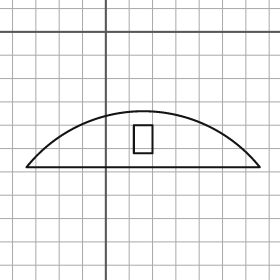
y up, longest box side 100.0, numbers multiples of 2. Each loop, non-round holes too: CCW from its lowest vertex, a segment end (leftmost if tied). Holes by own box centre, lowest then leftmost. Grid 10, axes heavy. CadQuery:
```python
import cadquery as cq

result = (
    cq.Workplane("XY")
    .moveTo(-34.0, -58.0)
    .lineTo(66.0, -58.0)
    .threePointArc((16.0, -34.0), (-34.0, -58.0))
    .close()
    .moveTo(12.0, -52.0)
    .lineTo(20.0, -52.0)
    .lineTo(20.0, -40.0)
    .lineTo(12.0, -40.0)
    .close()
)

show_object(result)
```